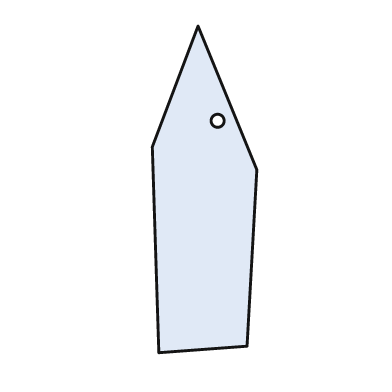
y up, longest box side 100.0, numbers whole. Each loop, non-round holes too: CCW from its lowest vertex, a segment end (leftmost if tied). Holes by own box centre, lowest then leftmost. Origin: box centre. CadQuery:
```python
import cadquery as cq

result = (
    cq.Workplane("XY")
    .moveTo(-14.0, -50.0)
    .lineTo(13.0, -48.0)
    .lineTo(16.0, 6.0)
    .lineTo(-2.0, 50.0)
    .lineTo(-16.0, 13.0)
    .close()
    .moveTo(4.0, 21.0)
    .circle(2.0)
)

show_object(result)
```